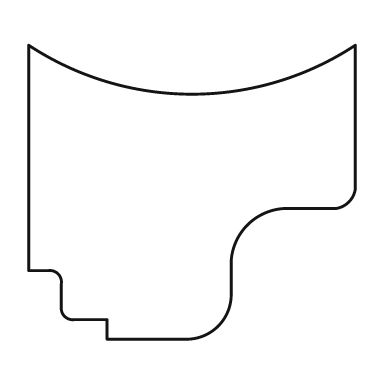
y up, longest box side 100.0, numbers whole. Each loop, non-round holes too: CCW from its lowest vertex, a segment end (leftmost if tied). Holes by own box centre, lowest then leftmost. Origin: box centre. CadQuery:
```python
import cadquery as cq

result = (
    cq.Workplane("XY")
    .moveTo(-26.0, -45.0)
    .lineTo(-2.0, -45.0)
    .threePointArc((8.0, -41.0), (12.0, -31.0))
    .lineTo(12.0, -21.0)
    .threePointArc((17.0, -10.0), (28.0, -5.0))
    .lineTo(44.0, -5.0)
    .threePointArc((48.0, -3.0), (50.0, 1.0))
    .lineTo(50.0, 45.0)
    .threePointArc((0.0, 30.0), (-50.0, 45.0))
    .lineTo(-50.0, -24.0)
    .lineTo(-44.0, -24.0)
    .threePointArc((-41.0, -25.0), (-40.0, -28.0))
    .lineTo(-40.0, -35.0)
    .threePointArc((-39.0, -38.0), (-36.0, -39.0))
    .lineTo(-26.0, -39.0)
    .close()
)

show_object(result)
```